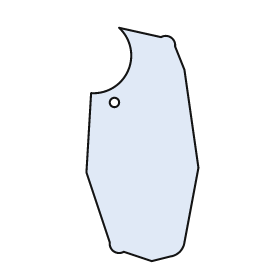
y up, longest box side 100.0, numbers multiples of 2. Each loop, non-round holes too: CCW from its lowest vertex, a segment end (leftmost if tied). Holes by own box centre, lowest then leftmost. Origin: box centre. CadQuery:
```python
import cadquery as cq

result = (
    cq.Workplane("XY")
    .moveTo(4.0, -50.0)
    .lineTo(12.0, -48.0)
    .threePointArc((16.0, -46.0), (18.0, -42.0))
    .lineTo(24.0, -10.0)
    .lineTo(18.0, 32.0)
    .lineTo(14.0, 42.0)
    .threePointArc((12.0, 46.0), (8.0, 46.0))
    .lineTo(-10.0, 50.0)
    .threePointArc((-6.0, 32.0), (-22.0, 22.0))
    .lineTo(-24.0, -12.0)
    .lineTo(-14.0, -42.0)
    .threePointArc((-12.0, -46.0), (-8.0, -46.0))
    .close()
    .moveTo(-12.0, 18.0)
    .circle(2.0)
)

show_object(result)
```